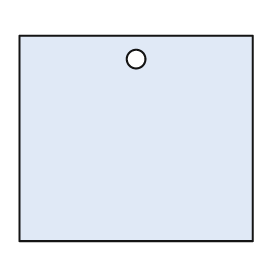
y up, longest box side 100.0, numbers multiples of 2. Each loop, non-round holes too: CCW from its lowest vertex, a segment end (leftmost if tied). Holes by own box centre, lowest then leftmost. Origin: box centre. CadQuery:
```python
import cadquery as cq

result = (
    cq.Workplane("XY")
    .moveTo(-50.0, -44.0)
    .lineTo(50.0, -44.0)
    .lineTo(50.0, 44.0)
    .lineTo(-50.0, 44.0)
    .close()
    .moveTo(0.0, 34.0)
    .circle(4.0)
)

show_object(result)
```